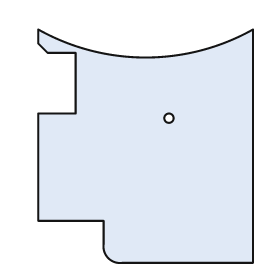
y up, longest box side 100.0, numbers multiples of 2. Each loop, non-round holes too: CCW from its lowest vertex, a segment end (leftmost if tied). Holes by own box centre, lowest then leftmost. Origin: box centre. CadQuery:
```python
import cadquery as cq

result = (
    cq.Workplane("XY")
    .moveTo(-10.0, -50.0)
    .lineTo(46.0, -50.0)
    .lineTo(46.0, 50.0)
    .threePointArc((0.0, 38.0), (-46.0, 50.0))
    .lineTo(-46.0, 44.0)
    .lineTo(-42.0, 40.0)
    .lineTo(-30.0, 40.0)
    .lineTo(-30.0, 14.0)
    .lineTo(-46.0, 14.0)
    .lineTo(-46.0, -32.0)
    .lineTo(-18.0, -32.0)
    .lineTo(-18.0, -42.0)
    .threePointArc((-16.0, -48.0), (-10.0, -50.0))
    .close()
    .moveTo(10.0, 12.0)
    .circle(2.0)
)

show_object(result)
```